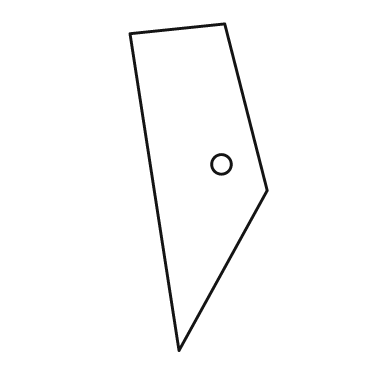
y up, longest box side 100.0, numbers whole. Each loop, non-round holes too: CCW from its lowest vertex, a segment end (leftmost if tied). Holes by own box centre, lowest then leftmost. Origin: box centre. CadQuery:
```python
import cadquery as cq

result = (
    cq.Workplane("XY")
    .moveTo(-6.0, -50.0)
    .lineTo(21.0, -1.0)
    .lineTo(8.0, 50.0)
    .lineTo(-21.0, 47.0)
    .close()
    .moveTo(7.0, 7.0)
    .circle(3.0)
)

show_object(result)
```